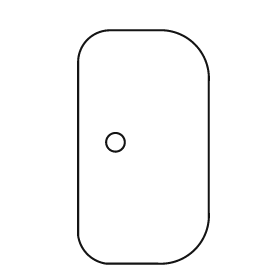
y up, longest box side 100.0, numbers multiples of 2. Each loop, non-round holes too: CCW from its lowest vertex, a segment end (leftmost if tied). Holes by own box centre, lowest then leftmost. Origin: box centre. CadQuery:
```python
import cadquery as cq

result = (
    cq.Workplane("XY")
    .moveTo(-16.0, -50.0)
    .lineTo(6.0, -50.0)
    .threePointArc((22.0, -44.0), (28.0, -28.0))
    .lineTo(28.0, 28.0)
    .threePointArc((22.0, 44.0), (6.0, 50.0))
    .lineTo(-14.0, 50.0)
    .threePointArc((-24.0, 46.0), (-28.0, 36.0))
    .lineTo(-28.0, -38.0)
    .threePointArc((-24.0, -46.0), (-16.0, -50.0))
    .close()
    .moveTo(-12.0, 2.0)
    .circle(4.0)
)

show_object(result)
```